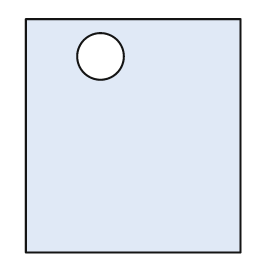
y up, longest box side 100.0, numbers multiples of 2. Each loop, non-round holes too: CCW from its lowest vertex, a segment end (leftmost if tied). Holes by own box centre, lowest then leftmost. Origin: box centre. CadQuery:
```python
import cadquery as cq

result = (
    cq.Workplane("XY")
    .moveTo(-46.0, -50.0)
    .lineTo(46.0, -50.0)
    .lineTo(46.0, 50.0)
    .lineTo(-46.0, 50.0)
    .close()
    .moveTo(-14.0, 34.0)
    .circle(10.0)
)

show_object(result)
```